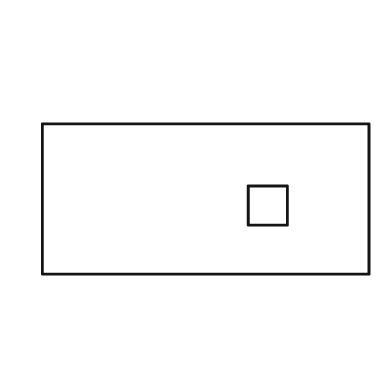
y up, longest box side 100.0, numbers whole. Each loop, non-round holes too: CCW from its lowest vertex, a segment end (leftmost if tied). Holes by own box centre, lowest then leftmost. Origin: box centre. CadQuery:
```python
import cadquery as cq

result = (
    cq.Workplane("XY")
    .moveTo(-50.0, -23.0)
    .lineTo(50.0, -23.0)
    .lineTo(50.0, 23.0)
    .lineTo(-50.0, 23.0)
    .close()
    .moveTo(13.0, -8.0)
    .lineTo(25.0, -8.0)
    .lineTo(25.0, 4.0)
    .lineTo(13.0, 4.0)
    .close()
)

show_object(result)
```